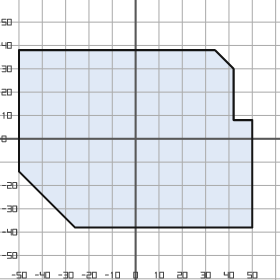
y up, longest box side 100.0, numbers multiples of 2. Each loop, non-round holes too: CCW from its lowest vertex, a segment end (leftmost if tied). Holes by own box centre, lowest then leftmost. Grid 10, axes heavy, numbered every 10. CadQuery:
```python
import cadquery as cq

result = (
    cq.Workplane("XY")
    .moveTo(-26.0, -38.0)
    .lineTo(50.0, -38.0)
    .lineTo(50.0, 8.0)
    .lineTo(42.0, 8.0)
    .lineTo(42.0, 30.0)
    .lineTo(34.0, 38.0)
    .lineTo(-50.0, 38.0)
    .lineTo(-50.0, -14.0)
    .close()
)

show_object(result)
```